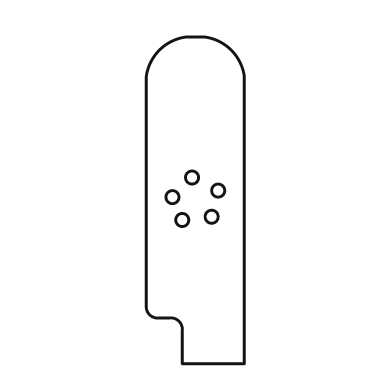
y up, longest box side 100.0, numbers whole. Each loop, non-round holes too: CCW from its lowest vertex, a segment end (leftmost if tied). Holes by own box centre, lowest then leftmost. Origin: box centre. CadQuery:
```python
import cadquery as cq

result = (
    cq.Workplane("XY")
    .moveTo(-4.0, -50.0)
    .lineTo(15.0, -50.0)
    .lineTo(15.0, 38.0)
    .threePointArc((11.0, 46.0), (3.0, 50.0))
    .lineTo(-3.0, 50.0)
    .threePointArc((-11.0, 46.0), (-15.0, 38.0))
    .lineTo(-15.0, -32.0)
    .threePointArc((-14.0, -35.0), (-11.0, -36.0))
    .lineTo(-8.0, -36.0)
    .threePointArc((-5.0, -37.0), (-4.0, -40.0))
    .close()
    .moveTo(-4.0, -6.0)
    .circle(2.0)
    .moveTo(5.0, -5.0)
    .circle(2.0)
    .moveTo(-7.0, 1.0)
    .circle(2.0)
    .moveTo(7.0, 3.0)
    .circle(2.0)
    .moveTo(-1.0, 7.0)
    .circle(2.0)
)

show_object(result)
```